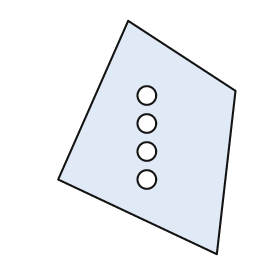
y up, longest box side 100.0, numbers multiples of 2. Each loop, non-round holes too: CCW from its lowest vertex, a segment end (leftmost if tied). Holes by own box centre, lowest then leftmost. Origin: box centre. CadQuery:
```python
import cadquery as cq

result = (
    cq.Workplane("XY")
    .moveTo(30.0, -50.0)
    .lineTo(38.0, 20.0)
    .lineTo(-8.0, 50.0)
    .lineTo(-38.0, -18.0)
    .close()
    .moveTo(0.0, -18.0)
    .circle(4.0)
    .moveTo(0.0, -6.0)
    .circle(4.0)
    .moveTo(0.0, 6.0)
    .circle(4.0)
    .moveTo(0.0, 18.0)
    .circle(4.0)
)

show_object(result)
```